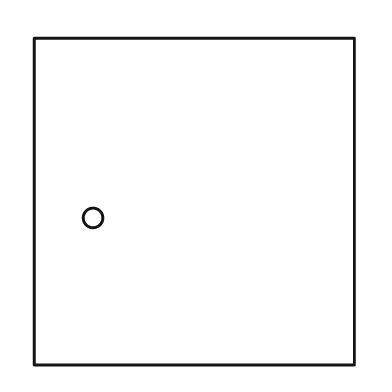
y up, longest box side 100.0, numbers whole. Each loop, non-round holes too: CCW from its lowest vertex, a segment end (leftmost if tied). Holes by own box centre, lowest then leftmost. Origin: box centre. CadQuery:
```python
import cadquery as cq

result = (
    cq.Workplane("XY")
    .moveTo(-49.0, -50.0)
    .lineTo(49.0, -50.0)
    .lineTo(49.0, 50.0)
    .lineTo(-49.0, 50.0)
    .close()
    .moveTo(-31.0, -5.0)
    .circle(3.0)
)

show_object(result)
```